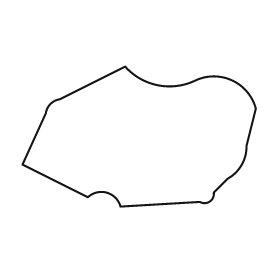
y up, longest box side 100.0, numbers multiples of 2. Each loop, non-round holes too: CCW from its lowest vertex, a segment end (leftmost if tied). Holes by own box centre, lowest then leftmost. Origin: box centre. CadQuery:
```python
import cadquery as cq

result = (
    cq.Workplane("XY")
    .moveTo(-8.0, -30.0)
    .lineTo(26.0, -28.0)
    .threePointArc((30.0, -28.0), (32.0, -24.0))
    .lineTo(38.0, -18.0)
    .threePointArc((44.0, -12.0), (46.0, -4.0))
    .lineTo(50.0, 12.0)
    .threePointArc((40.0, 24.0), (24.0, 24.0))
    .threePointArc((8.0, 22.0), (-6.0, 30.0))
    .lineTo(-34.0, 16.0)
    .threePointArc((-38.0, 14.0), (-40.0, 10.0))
    .lineTo(-50.0, -12.0)
    .lineTo(-22.0, -26.0)
    .threePointArc((-14.0, -24.0), (-8.0, -30.0))
    .close()
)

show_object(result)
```